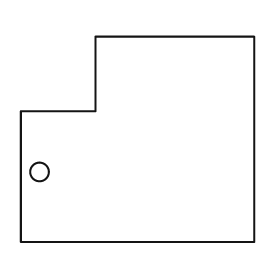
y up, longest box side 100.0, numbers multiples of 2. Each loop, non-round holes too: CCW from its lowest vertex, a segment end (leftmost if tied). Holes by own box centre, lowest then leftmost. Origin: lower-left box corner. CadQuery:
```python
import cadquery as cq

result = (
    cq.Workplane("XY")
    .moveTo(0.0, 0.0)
    .lineTo(100.0, 0.0)
    .lineTo(100.0, 88.0)
    .lineTo(32.0, 88.0)
    .lineTo(32.0, 56.0)
    .lineTo(0.0, 56.0)
    .close()
    .moveTo(8.0, 30.0)
    .circle(4.0)
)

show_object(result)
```